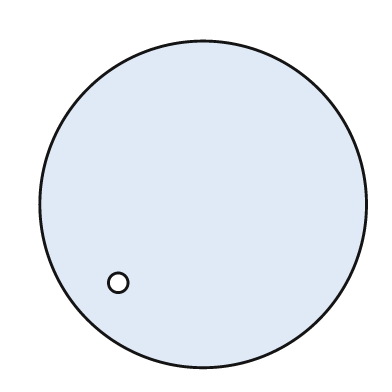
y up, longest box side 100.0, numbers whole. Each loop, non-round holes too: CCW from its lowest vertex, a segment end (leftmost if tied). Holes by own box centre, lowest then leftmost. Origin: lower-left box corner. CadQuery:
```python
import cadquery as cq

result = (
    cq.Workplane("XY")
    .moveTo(50.0, 50.0)
    .circle(50.0)
    .moveTo(24.0, 26.0)
    .circle(3.0)
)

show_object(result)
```